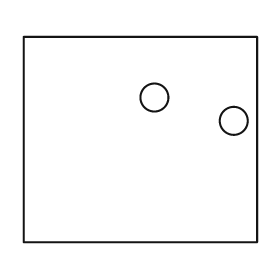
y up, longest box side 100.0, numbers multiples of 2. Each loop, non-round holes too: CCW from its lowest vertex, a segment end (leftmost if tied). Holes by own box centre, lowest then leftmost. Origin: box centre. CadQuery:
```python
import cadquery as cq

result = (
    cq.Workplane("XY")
    .moveTo(-50.0, -44.0)
    .lineTo(50.0, -44.0)
    .lineTo(50.0, 44.0)
    .lineTo(-50.0, 44.0)
    .close()
    .moveTo(40.0, 8.0)
    .circle(6.0)
    .moveTo(6.0, 18.0)
    .circle(6.0)
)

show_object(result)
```